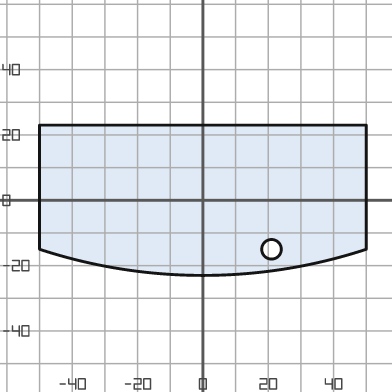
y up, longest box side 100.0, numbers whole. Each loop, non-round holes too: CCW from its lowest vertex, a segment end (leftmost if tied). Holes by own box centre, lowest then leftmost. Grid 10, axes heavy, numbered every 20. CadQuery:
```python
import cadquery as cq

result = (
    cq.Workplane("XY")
    .moveTo(-50.0, -15.0)
    .threePointArc((0.0, -23.0), (50.0, -15.0))
    .lineTo(50.0, 23.0)
    .lineTo(-50.0, 23.0)
    .close()
    .moveTo(21.0, -15.0)
    .circle(3.0)
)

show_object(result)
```